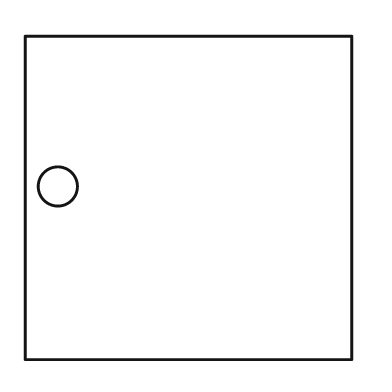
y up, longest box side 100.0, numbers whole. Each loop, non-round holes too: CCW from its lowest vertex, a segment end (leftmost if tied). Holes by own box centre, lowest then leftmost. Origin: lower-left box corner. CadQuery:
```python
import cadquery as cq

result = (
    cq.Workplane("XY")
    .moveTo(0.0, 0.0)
    .lineTo(100.0, 0.0)
    .lineTo(100.0, 99.0)
    .lineTo(0.0, 99.0)
    .close()
    .moveTo(10.0, 53.0)
    .circle(6.0)
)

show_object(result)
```